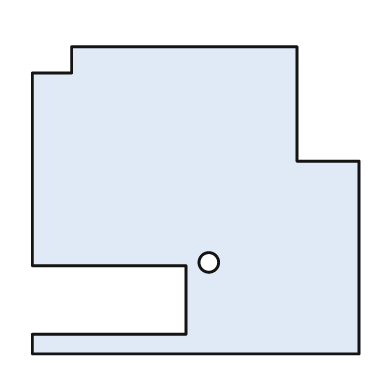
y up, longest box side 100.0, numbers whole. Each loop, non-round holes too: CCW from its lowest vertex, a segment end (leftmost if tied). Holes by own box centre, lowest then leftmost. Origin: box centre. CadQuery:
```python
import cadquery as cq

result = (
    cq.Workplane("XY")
    .moveTo(-50.0, -47.0)
    .lineTo(50.0, -47.0)
    .lineTo(50.0, 12.0)
    .lineTo(31.0, 12.0)
    .lineTo(31.0, 47.0)
    .lineTo(-38.0, 47.0)
    .lineTo(-38.0, 39.0)
    .lineTo(-50.0, 39.0)
    .lineTo(-50.0, -20.0)
    .lineTo(-3.0, -20.0)
    .lineTo(-3.0, -41.0)
    .lineTo(-50.0, -41.0)
    .close()
    .moveTo(4.0, -19.0)
    .circle(3.0)
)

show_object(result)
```